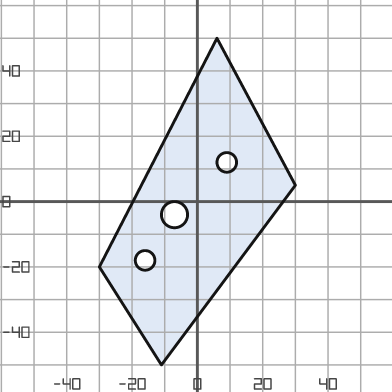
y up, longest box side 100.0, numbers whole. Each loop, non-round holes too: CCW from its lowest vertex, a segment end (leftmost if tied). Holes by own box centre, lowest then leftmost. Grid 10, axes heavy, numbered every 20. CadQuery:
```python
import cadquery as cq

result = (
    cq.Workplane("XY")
    .moveTo(-11.0, -50.0)
    .lineTo(30.0, 5.0)
    .lineTo(6.0, 50.0)
    .lineTo(-30.0, -20.0)
    .close()
    .moveTo(-16.0, -18.0)
    .circle(3.0)
    .moveTo(-7.0, -4.0)
    .circle(4.0)
    .moveTo(9.0, 12.0)
    .circle(3.0)
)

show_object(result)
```